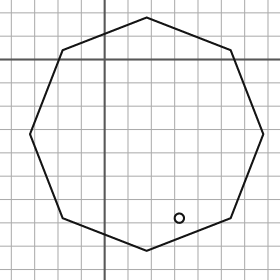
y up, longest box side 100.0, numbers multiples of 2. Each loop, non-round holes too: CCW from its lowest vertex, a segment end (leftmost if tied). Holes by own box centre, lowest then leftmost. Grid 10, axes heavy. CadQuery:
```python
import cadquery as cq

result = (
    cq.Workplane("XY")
    .moveTo(18.0, -82.0)
    .lineTo(54.0, -68.0)
    .lineTo(68.0, -32.0)
    .lineTo(54.0, 4.0)
    .lineTo(18.0, 18.0)
    .lineTo(-18.0, 4.0)
    .lineTo(-32.0, -32.0)
    .lineTo(-18.0, -68.0)
    .close()
    .moveTo(32.0, -68.0)
    .circle(2.0)
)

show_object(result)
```